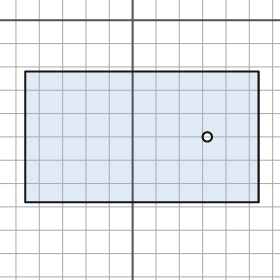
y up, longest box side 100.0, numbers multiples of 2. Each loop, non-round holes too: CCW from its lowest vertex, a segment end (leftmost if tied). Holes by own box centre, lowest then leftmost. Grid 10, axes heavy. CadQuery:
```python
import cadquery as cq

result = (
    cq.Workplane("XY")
    .moveTo(-46.0, -78.0)
    .lineTo(54.0, -78.0)
    .lineTo(54.0, -22.0)
    .lineTo(-46.0, -22.0)
    .close()
    .moveTo(32.0, -50.0)
    .circle(2.0)
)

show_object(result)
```